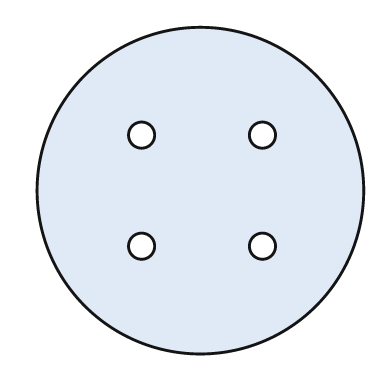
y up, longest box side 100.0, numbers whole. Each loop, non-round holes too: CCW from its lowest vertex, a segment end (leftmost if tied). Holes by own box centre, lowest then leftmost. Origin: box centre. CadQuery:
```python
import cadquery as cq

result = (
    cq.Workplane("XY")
    .moveTo(0.0, 0.0)
    .circle(50.0)
    .moveTo(-18.0, -17.0)
    .circle(4.0)
    .moveTo(19.0, -17.0)
    .circle(4.0)
    .moveTo(-18.0, 17.0)
    .circle(4.0)
    .moveTo(19.0, 17.0)
    .circle(4.0)
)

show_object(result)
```